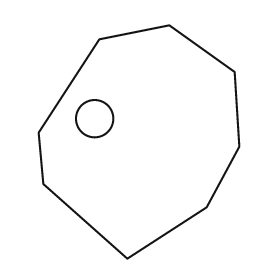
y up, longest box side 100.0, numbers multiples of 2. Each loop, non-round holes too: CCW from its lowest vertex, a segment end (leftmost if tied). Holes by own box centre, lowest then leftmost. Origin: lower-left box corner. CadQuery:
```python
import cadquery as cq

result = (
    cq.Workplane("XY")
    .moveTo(38.0, 0.0)
    .lineTo(72.0, 22.0)
    .lineTo(86.0, 48.0)
    .lineTo(84.0, 80.0)
    .lineTo(56.0, 100.0)
    .lineTo(26.0, 94.0)
    .lineTo(0.0, 54.0)
    .lineTo(2.0, 32.0)
    .close()
    .moveTo(24.0, 60.0)
    .circle(8.0)
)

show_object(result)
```